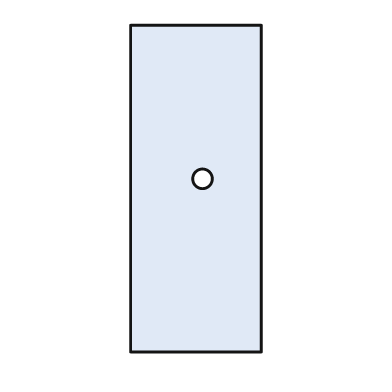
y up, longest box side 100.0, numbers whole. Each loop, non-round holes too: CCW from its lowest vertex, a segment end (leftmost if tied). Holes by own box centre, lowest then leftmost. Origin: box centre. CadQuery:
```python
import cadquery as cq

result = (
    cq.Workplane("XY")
    .moveTo(-20.0, -50.0)
    .lineTo(20.0, -50.0)
    .lineTo(20.0, 50.0)
    .lineTo(-20.0, 50.0)
    .close()
    .moveTo(2.0, 3.0)
    .circle(3.0)
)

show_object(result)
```